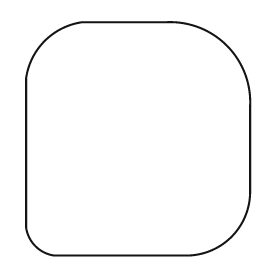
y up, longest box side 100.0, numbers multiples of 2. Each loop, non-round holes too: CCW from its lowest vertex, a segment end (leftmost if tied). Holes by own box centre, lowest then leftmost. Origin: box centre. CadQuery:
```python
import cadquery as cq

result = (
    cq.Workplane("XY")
    .moveTo(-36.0, -50.0)
    .lineTo(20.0, -50.0)
    .threePointArc((40.0, -42.0), (48.0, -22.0))
    .lineTo(48.0, 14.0)
    .threePointArc((38.0, 40.0), (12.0, 50.0))
    .lineTo(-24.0, 50.0)
    .threePointArc((-40.0, 42.0), (-48.0, 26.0))
    .lineTo(-48.0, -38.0)
    .threePointArc((-44.0, -46.0), (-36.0, -50.0))
    .close()
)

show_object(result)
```